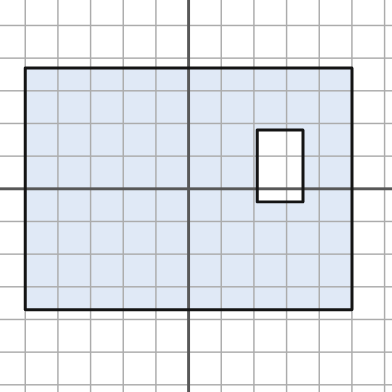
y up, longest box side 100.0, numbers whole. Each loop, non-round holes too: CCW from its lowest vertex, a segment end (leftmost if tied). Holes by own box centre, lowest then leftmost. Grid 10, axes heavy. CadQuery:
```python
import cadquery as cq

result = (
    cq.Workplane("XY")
    .moveTo(-50.0, -37.0)
    .lineTo(50.0, -37.0)
    .lineTo(50.0, 37.0)
    .lineTo(-50.0, 37.0)
    .close()
    .moveTo(21.0, -4.0)
    .lineTo(35.0, -4.0)
    .lineTo(35.0, 18.0)
    .lineTo(21.0, 18.0)
    .close()
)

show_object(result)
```